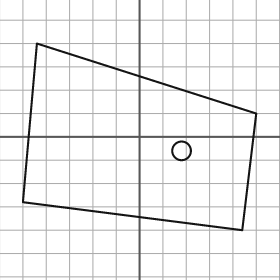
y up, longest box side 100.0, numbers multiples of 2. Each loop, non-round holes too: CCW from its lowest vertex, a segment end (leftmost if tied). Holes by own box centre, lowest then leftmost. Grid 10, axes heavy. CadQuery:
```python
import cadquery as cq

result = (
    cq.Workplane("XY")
    .moveTo(44.0, -40.0)
    .lineTo(50.0, 10.0)
    .lineTo(-44.0, 40.0)
    .lineTo(-50.0, -28.0)
    .close()
    .moveTo(18.0, -6.0)
    .circle(4.0)
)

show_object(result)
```